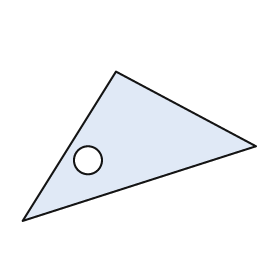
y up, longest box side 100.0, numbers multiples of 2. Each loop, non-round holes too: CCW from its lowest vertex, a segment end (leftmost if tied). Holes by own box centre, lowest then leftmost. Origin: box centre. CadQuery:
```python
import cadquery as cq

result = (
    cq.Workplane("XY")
    .moveTo(-50.0, -32.0)
    .lineTo(50.0, 0.0)
    .lineTo(-10.0, 32.0)
    .close()
    .moveTo(-22.0, -6.0)
    .circle(6.0)
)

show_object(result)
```